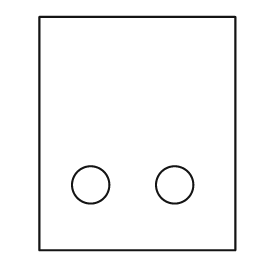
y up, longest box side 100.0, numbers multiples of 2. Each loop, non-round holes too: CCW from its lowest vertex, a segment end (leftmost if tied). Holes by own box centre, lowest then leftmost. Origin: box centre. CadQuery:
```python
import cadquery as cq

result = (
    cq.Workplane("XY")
    .moveTo(-42.0, -50.0)
    .lineTo(42.0, -50.0)
    .lineTo(42.0, 50.0)
    .lineTo(-42.0, 50.0)
    .close()
    .moveTo(-20.0, -22.0)
    .circle(8.0)
    .moveTo(16.0, -22.0)
    .circle(8.0)
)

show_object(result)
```